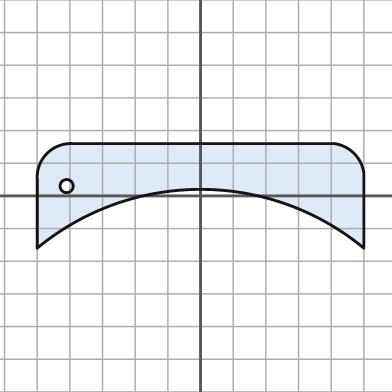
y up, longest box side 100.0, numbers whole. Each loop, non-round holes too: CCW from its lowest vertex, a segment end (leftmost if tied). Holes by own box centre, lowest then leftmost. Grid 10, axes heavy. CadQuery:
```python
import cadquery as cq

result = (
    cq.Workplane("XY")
    .moveTo(-50.0, -16.0)
    .threePointArc((0.0, 2.0), (50.0, -16.0))
    .lineTo(50.0, 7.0)
    .threePointArc((47.0, 13.0), (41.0, 16.0))
    .lineTo(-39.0, 16.0)
    .threePointArc((-47.0, 13.0), (-50.0, 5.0))
    .close()
    .moveTo(-41.0, 3.0)
    .circle(2.0)
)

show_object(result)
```